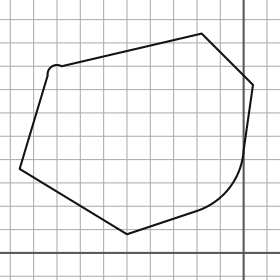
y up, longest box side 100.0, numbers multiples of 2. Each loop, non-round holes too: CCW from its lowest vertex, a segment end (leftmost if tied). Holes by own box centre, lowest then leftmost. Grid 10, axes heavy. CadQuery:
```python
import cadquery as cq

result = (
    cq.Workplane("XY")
    .moveTo(-50.0, 8.0)
    .lineTo(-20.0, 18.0)
    .threePointArc((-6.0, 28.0), (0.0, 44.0))
    .lineTo(4.0, 72.0)
    .lineTo(-18.0, 94.0)
    .lineTo(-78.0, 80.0)
    .threePointArc((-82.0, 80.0), (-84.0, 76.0))
    .lineTo(-96.0, 36.0)
    .close()
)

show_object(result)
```